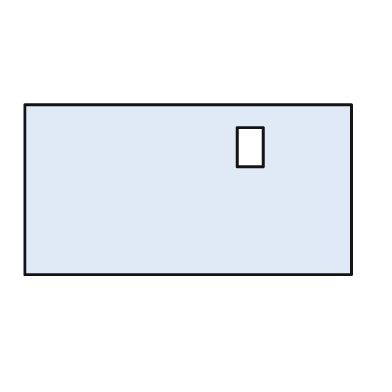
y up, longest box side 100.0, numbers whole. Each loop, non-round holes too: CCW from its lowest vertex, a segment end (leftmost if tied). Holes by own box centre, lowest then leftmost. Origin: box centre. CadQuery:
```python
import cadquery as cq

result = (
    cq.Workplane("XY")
    .moveTo(-50.0, -26.0)
    .lineTo(50.0, -26.0)
    .lineTo(50.0, 26.0)
    .lineTo(-50.0, 26.0)
    .close()
    .moveTo(15.0, 7.0)
    .lineTo(23.0, 7.0)
    .lineTo(23.0, 19.0)
    .lineTo(15.0, 19.0)
    .close()
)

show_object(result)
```